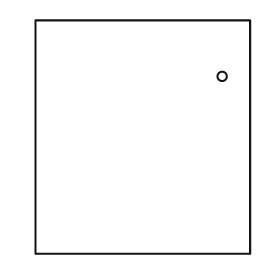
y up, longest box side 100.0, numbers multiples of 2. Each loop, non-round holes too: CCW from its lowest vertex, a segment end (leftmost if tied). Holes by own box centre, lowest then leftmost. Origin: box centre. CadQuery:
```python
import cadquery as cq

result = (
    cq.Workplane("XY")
    .moveTo(-46.0, -50.0)
    .lineTo(46.0, -50.0)
    .lineTo(46.0, 50.0)
    .lineTo(-46.0, 50.0)
    .close()
    .moveTo(34.0, 26.0)
    .circle(2.0)
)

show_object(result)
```